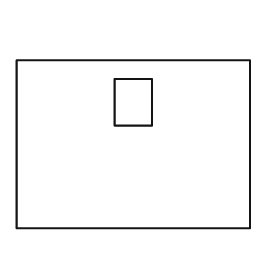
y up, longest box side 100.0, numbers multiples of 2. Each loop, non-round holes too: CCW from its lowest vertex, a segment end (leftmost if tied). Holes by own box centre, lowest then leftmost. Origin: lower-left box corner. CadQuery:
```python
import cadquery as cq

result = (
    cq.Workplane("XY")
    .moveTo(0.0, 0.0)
    .lineTo(100.0, 0.0)
    .lineTo(100.0, 72.0)
    .lineTo(0.0, 72.0)
    .close()
    .moveTo(42.0, 44.0)
    .lineTo(58.0, 44.0)
    .lineTo(58.0, 64.0)
    .lineTo(42.0, 64.0)
    .close()
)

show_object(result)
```